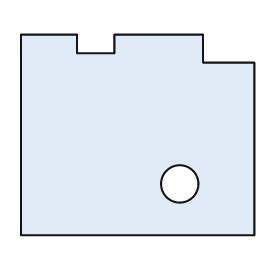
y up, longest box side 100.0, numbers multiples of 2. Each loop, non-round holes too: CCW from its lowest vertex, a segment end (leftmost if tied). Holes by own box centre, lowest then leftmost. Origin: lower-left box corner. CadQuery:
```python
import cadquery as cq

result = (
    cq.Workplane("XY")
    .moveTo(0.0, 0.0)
    .lineTo(100.0, 0.0)
    .lineTo(100.0, 74.0)
    .lineTo(78.0, 74.0)
    .lineTo(78.0, 86.0)
    .lineTo(40.0, 86.0)
    .lineTo(40.0, 78.0)
    .lineTo(24.0, 78.0)
    .lineTo(24.0, 86.0)
    .lineTo(0.0, 86.0)
    .close()
    .moveTo(68.0, 22.0)
    .circle(8.0)
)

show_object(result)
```